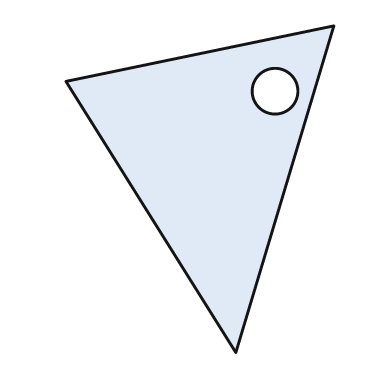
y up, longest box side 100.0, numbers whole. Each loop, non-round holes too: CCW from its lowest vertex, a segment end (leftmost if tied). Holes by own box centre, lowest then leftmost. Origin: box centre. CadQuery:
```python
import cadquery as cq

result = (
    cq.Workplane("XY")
    .moveTo(11.0, -50.0)
    .lineTo(41.0, 50.0)
    .lineTo(-41.0, 33.0)
    .close()
    .moveTo(23.0, 30.0)
    .circle(7.0)
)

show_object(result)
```